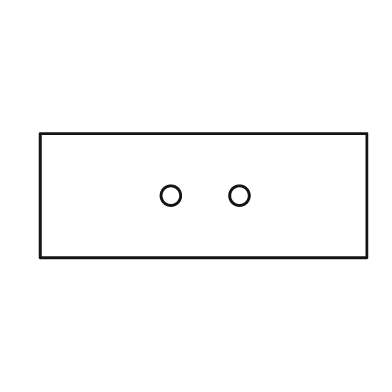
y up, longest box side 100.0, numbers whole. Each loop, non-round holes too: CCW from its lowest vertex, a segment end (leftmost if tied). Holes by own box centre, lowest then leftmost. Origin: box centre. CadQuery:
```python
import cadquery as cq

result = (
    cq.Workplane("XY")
    .moveTo(-50.0, -19.0)
    .lineTo(50.0, -19.0)
    .lineTo(50.0, 19.0)
    .lineTo(-50.0, 19.0)
    .close()
    .moveTo(-10.0, 0.0)
    .circle(3.0)
    .moveTo(11.0, 0.0)
    .circle(3.0)
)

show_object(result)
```